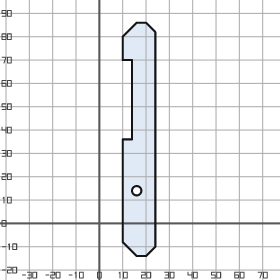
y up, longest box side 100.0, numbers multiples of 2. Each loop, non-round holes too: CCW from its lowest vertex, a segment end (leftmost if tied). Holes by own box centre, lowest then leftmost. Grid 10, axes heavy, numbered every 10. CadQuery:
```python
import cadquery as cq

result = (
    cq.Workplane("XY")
    .moveTo(16.0, -14.0)
    .lineTo(20.0, -14.0)
    .lineTo(24.0, -10.0)
    .lineTo(24.0, 82.0)
    .lineTo(20.0, 86.0)
    .lineTo(16.0, 86.0)
    .lineTo(10.0, 80.0)
    .lineTo(10.0, 70.0)
    .lineTo(14.0, 70.0)
    .lineTo(14.0, 36.0)
    .lineTo(10.0, 36.0)
    .lineTo(10.0, -8.0)
    .close()
    .moveTo(16.0, 14.0)
    .circle(2.0)
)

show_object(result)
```